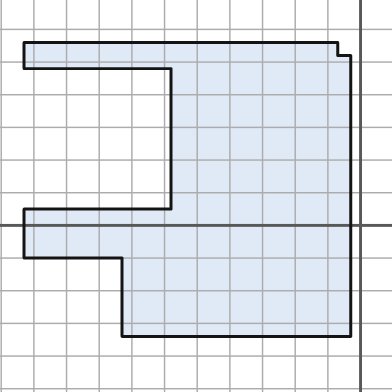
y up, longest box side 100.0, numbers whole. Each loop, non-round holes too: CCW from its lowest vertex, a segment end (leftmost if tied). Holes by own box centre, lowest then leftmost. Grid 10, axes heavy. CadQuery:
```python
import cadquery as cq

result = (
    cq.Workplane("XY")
    .moveTo(-73.0, -34.0)
    .lineTo(-3.0, -34.0)
    .lineTo(-3.0, 52.0)
    .lineTo(-7.0, 52.0)
    .lineTo(-7.0, 56.0)
    .lineTo(-103.0, 56.0)
    .lineTo(-103.0, 48.0)
    .lineTo(-58.0, 48.0)
    .lineTo(-58.0, 5.0)
    .lineTo(-103.0, 5.0)
    .lineTo(-103.0, -10.0)
    .lineTo(-73.0, -10.0)
    .close()
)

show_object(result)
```